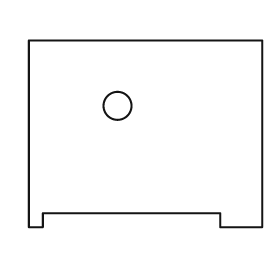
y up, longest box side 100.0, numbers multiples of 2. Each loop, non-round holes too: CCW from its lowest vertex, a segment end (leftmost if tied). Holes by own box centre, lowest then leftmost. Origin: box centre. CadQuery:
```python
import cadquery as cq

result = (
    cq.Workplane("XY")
    .moveTo(-50.0, -40.0)
    .lineTo(-44.0, -40.0)
    .lineTo(-44.0, -34.0)
    .lineTo(32.0, -34.0)
    .lineTo(32.0, -40.0)
    .lineTo(50.0, -40.0)
    .lineTo(50.0, 40.0)
    .lineTo(-50.0, 40.0)
    .close()
    .moveTo(-12.0, 12.0)
    .circle(6.0)
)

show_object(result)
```